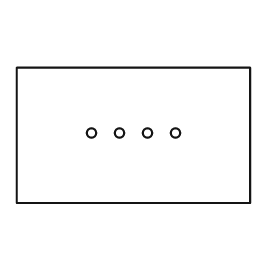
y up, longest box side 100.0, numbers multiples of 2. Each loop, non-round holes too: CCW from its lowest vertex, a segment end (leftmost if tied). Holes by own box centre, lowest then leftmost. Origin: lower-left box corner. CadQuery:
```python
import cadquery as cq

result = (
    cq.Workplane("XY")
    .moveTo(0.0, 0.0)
    .lineTo(100.0, 0.0)
    .lineTo(100.0, 58.0)
    .lineTo(0.0, 58.0)
    .close()
    .moveTo(32.0, 30.0)
    .circle(2.0)
    .moveTo(44.0, 30.0)
    .circle(2.0)
    .moveTo(56.0, 30.0)
    .circle(2.0)
    .moveTo(68.0, 30.0)
    .circle(2.0)
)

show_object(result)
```